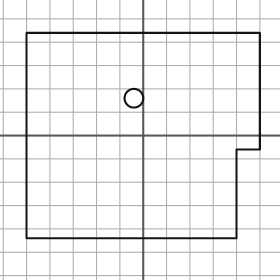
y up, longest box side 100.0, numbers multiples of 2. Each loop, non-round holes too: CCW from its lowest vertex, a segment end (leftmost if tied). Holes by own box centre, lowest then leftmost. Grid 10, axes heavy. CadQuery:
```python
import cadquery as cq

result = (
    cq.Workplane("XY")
    .moveTo(-50.0, -44.0)
    .lineTo(40.0, -44.0)
    .lineTo(40.0, -6.0)
    .lineTo(50.0, -6.0)
    .lineTo(50.0, 44.0)
    .lineTo(-50.0, 44.0)
    .close()
    .moveTo(-4.0, 16.0)
    .circle(4.0)
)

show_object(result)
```